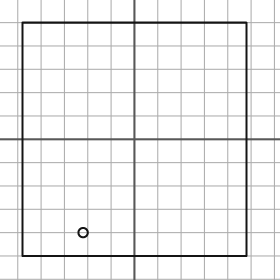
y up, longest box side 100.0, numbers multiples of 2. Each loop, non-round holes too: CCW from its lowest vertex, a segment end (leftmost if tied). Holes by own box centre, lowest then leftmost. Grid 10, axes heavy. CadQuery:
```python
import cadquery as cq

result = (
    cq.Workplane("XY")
    .moveTo(-48.0, -50.0)
    .lineTo(48.0, -50.0)
    .lineTo(48.0, 50.0)
    .lineTo(-48.0, 50.0)
    .close()
    .moveTo(-22.0, -40.0)
    .circle(2.0)
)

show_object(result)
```